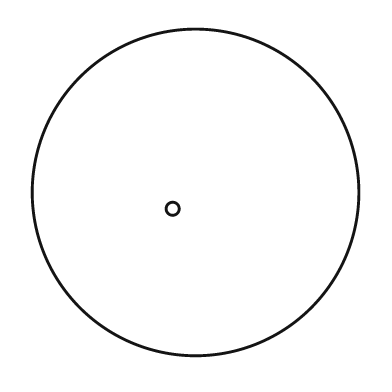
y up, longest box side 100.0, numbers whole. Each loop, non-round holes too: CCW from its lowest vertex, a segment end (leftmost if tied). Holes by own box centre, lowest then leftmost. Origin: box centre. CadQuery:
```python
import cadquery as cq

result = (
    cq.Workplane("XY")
    .moveTo(0.0, 0.0)
    .circle(50.0)
    .moveTo(-7.0, -5.0)
    .circle(2.0)
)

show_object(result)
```